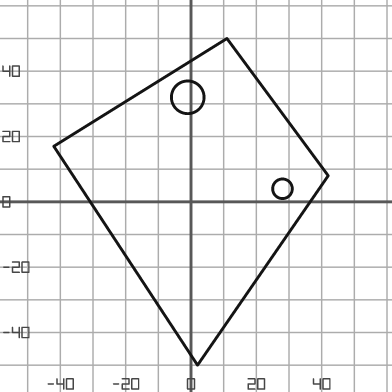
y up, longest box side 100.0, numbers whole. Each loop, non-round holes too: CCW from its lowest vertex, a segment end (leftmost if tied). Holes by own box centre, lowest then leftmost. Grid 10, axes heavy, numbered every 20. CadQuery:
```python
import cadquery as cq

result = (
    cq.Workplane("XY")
    .moveTo(2.0, -50.0)
    .lineTo(42.0, 8.0)
    .lineTo(11.0, 50.0)
    .lineTo(-42.0, 17.0)
    .close()
    .moveTo(28.0, 4.0)
    .circle(3.0)
    .moveTo(-1.0, 32.0)
    .circle(5.0)
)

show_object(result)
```